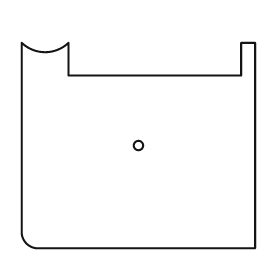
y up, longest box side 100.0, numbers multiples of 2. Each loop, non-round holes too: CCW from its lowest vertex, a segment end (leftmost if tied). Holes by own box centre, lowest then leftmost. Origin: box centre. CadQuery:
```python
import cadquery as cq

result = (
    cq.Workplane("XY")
    .moveTo(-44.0, -44.0)
    .lineTo(50.0, -44.0)
    .lineTo(50.0, 44.0)
    .lineTo(44.0, 44.0)
    .lineTo(44.0, 30.0)
    .lineTo(-30.0, 30.0)
    .lineTo(-30.0, 44.0)
    .threePointArc((-40.0, 40.0), (-50.0, 44.0))
    .lineTo(-50.0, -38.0)
    .threePointArc((-48.0, -42.0), (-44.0, -44.0))
    .close()
    .moveTo(0.0, 0.0)
    .circle(2.0)
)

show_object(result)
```